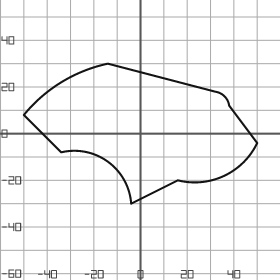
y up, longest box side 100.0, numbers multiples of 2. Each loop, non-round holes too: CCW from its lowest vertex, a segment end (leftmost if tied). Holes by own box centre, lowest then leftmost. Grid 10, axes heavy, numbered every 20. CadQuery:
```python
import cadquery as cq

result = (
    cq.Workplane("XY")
    .moveTo(-4.0, -30.0)
    .lineTo(16.0, -20.0)
    .threePointArc((36.0, -18.0), (50.0, -4.0))
    .lineTo(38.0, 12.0)
    .threePointArc((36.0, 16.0), (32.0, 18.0))
    .lineTo(-14.0, 30.0)
    .threePointArc((-34.0, 22.0), (-50.0, 8.0))
    .lineTo(-34.0, -8.0)
    .threePointArc((-14.0, -12.0), (-4.0, -30.0))
    .close()
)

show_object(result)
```